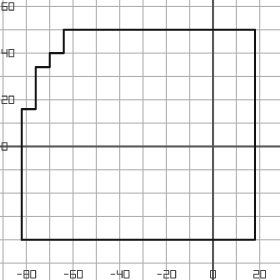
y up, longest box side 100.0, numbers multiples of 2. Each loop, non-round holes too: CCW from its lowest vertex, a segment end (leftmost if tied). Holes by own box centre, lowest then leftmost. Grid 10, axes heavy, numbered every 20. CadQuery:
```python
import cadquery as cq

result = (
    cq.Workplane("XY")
    .moveTo(-82.0, -40.0)
    .lineTo(18.0, -40.0)
    .lineTo(18.0, 50.0)
    .lineTo(-64.0, 50.0)
    .lineTo(-64.0, 40.0)
    .lineTo(-70.0, 40.0)
    .lineTo(-70.0, 34.0)
    .lineTo(-76.0, 34.0)
    .lineTo(-76.0, 16.0)
    .lineTo(-82.0, 16.0)
    .close()
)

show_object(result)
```